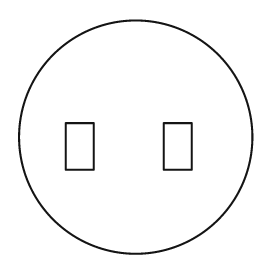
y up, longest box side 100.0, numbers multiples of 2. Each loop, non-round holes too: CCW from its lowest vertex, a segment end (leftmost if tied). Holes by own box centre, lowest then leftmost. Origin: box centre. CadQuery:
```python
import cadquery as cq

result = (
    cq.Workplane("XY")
    .moveTo(0.0, 0.0)
    .circle(50.0)
    .moveTo(-30.0, -14.0)
    .lineTo(-18.0, -14.0)
    .lineTo(-18.0, 6.0)
    .lineTo(-30.0, 6.0)
    .close()
    .moveTo(12.0, -14.0)
    .lineTo(24.0, -14.0)
    .lineTo(24.0, 6.0)
    .lineTo(12.0, 6.0)
    .close()
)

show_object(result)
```